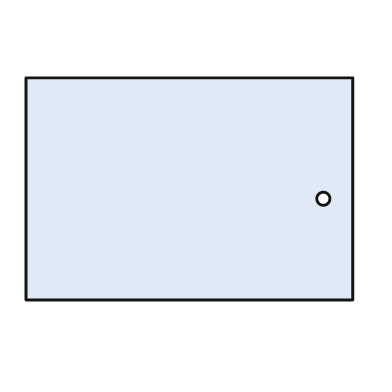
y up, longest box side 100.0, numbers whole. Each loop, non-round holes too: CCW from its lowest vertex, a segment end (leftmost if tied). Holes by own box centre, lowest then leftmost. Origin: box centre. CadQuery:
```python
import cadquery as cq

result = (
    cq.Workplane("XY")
    .moveTo(-50.0, -34.0)
    .lineTo(50.0, -34.0)
    .lineTo(50.0, 34.0)
    .lineTo(-50.0, 34.0)
    .close()
    .moveTo(41.0, -3.0)
    .circle(2.0)
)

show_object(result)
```